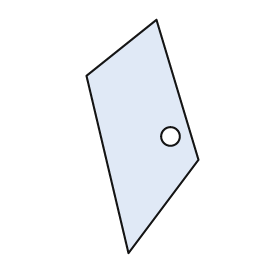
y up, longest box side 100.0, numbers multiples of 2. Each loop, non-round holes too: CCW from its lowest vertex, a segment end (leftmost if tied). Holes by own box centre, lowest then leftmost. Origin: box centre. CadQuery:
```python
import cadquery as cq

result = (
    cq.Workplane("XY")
    .moveTo(-6.0, -50.0)
    .lineTo(24.0, -10.0)
    .lineTo(6.0, 50.0)
    .lineTo(-24.0, 26.0)
    .close()
    .moveTo(12.0, 0.0)
    .circle(4.0)
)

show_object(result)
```